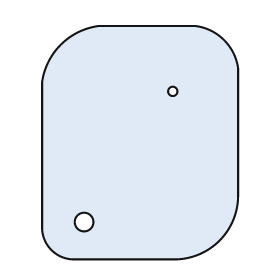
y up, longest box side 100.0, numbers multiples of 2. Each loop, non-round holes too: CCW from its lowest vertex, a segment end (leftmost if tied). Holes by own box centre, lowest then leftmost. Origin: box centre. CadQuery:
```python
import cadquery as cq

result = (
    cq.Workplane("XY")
    .moveTo(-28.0, -50.0)
    .lineTo(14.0, -50.0)
    .threePointArc((34.0, -42.0), (42.0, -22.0))
    .lineTo(42.0, 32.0)
    .threePointArc((36.0, 44.0), (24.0, 50.0))
    .lineTo(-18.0, 50.0)
    .threePointArc((-34.0, 42.0), (-42.0, 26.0))
    .lineTo(-42.0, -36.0)
    .threePointArc((-38.0, -46.0), (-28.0, -50.0))
    .close()
    .moveTo(-24.0, -34.0)
    .circle(4.0)
    .moveTo(14.0, 22.0)
    .circle(2.0)
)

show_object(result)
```